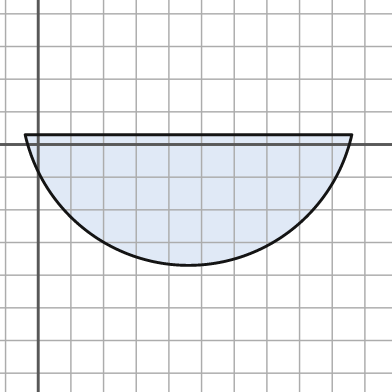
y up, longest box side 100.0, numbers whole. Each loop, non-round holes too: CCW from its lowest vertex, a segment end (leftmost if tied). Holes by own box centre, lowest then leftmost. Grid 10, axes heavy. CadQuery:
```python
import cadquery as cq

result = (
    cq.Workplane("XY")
    .moveTo(-4.0, 3.0)
    .threePointArc((46.0, -37.0), (96.0, 3.0))
    .close()
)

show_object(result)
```